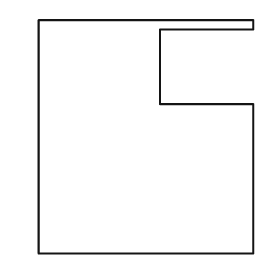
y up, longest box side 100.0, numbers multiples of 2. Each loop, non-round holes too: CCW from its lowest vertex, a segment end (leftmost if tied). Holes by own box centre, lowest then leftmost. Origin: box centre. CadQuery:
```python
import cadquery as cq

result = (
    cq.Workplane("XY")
    .moveTo(-46.0, -50.0)
    .lineTo(46.0, -50.0)
    .lineTo(46.0, 14.0)
    .lineTo(6.0, 14.0)
    .lineTo(6.0, 46.0)
    .lineTo(46.0, 46.0)
    .lineTo(46.0, 50.0)
    .lineTo(-46.0, 50.0)
    .close()
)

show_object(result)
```